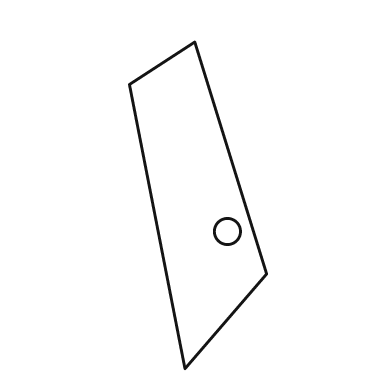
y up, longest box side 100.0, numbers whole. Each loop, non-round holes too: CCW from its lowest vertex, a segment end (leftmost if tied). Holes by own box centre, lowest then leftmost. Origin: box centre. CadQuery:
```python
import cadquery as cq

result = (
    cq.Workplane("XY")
    .moveTo(-4.0, -50.0)
    .lineTo(21.0, -21.0)
    .lineTo(-1.0, 50.0)
    .lineTo(-21.0, 37.0)
    .close()
    .moveTo(9.0, -8.0)
    .circle(4.0)
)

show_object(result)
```